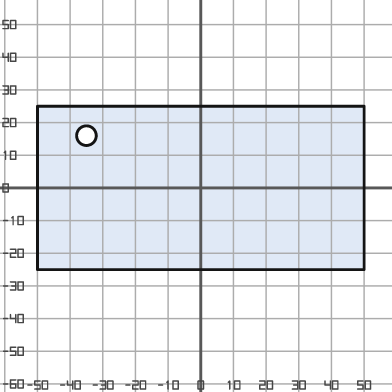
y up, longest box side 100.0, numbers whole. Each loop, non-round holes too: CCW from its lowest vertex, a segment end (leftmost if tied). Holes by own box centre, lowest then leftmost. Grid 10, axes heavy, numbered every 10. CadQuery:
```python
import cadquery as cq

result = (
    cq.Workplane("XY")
    .moveTo(-50.0, -25.0)
    .lineTo(50.0, -25.0)
    .lineTo(50.0, 25.0)
    .lineTo(-50.0, 25.0)
    .close()
    .moveTo(-35.0, 16.0)
    .circle(3.0)
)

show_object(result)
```